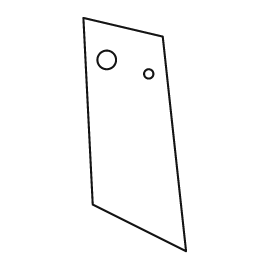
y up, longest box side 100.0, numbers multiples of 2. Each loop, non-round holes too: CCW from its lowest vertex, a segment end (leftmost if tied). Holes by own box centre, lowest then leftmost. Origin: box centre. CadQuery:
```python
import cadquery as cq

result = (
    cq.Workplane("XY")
    .moveTo(22.0, -50.0)
    .lineTo(12.0, 42.0)
    .lineTo(-22.0, 50.0)
    .lineTo(-18.0, -30.0)
    .close()
    .moveTo(6.0, 26.0)
    .circle(2.0)
    .moveTo(-12.0, 32.0)
    .circle(4.0)
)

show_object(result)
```